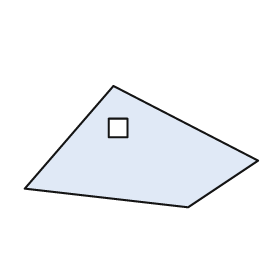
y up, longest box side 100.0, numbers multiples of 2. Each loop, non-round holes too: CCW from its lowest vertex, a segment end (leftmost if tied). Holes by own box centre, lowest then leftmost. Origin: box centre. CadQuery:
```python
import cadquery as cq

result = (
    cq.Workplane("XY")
    .moveTo(20.0, -26.0)
    .lineTo(50.0, -6.0)
    .lineTo(-12.0, 26.0)
    .lineTo(-50.0, -18.0)
    .close()
    .moveTo(-14.0, 4.0)
    .lineTo(-6.0, 4.0)
    .lineTo(-6.0, 12.0)
    .lineTo(-14.0, 12.0)
    .close()
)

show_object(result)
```